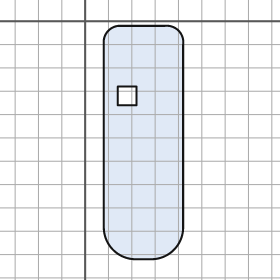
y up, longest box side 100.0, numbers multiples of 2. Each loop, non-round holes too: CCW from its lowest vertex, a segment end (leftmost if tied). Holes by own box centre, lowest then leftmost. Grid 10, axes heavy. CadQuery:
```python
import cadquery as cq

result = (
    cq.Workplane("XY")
    .moveTo(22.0, -102.0)
    .lineTo(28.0, -102.0)
    .threePointArc((38.0, -98.0), (42.0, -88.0))
    .lineTo(42.0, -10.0)
    .threePointArc((40.0, -4.0), (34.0, -2.0))
    .lineTo(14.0, -2.0)
    .threePointArc((10.0, -4.0), (8.0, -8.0))
    .lineTo(8.0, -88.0)
    .threePointArc((12.0, -98.0), (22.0, -102.0))
    .close()
    .moveTo(14.0, -36.0)
    .lineTo(22.0, -36.0)
    .lineTo(22.0, -28.0)
    .lineTo(14.0, -28.0)
    .close()
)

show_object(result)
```